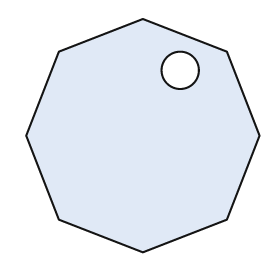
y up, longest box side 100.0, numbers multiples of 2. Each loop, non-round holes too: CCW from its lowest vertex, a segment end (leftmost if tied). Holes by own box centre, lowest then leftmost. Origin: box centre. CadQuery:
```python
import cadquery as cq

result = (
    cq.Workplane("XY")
    .moveTo(0.0, -50.0)
    .lineTo(36.0, -36.0)
    .lineTo(50.0, 0.0)
    .lineTo(36.0, 36.0)
    .lineTo(0.0, 50.0)
    .lineTo(-36.0, 36.0)
    .lineTo(-50.0, 0.0)
    .lineTo(-36.0, -36.0)
    .close()
    .moveTo(16.0, 28.0)
    .circle(8.0)
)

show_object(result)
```